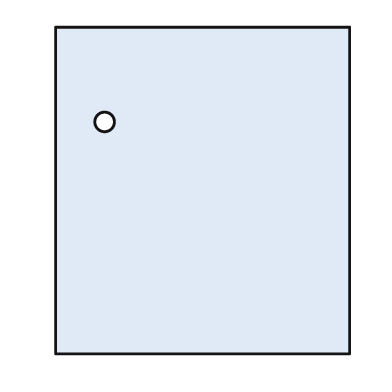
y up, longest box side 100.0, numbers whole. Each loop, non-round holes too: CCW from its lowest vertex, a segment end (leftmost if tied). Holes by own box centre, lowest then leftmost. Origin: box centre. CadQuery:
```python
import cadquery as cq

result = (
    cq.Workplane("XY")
    .moveTo(-45.0, -50.0)
    .lineTo(45.0, -50.0)
    .lineTo(45.0, 50.0)
    .lineTo(-45.0, 50.0)
    .close()
    .moveTo(-30.0, 21.0)
    .circle(3.0)
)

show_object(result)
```